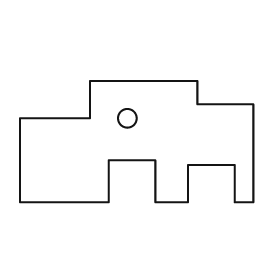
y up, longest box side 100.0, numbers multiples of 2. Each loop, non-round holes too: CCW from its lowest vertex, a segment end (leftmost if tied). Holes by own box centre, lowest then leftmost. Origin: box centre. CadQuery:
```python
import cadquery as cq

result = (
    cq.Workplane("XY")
    .moveTo(-50.0, -26.0)
    .lineTo(-12.0, -26.0)
    .lineTo(-12.0, -8.0)
    .lineTo(8.0, -8.0)
    .lineTo(8.0, -26.0)
    .lineTo(22.0, -26.0)
    .lineTo(22.0, -10.0)
    .lineTo(42.0, -10.0)
    .lineTo(42.0, -26.0)
    .lineTo(50.0, -26.0)
    .lineTo(50.0, 16.0)
    .lineTo(26.0, 16.0)
    .lineTo(26.0, 26.0)
    .lineTo(-20.0, 26.0)
    .lineTo(-20.0, 10.0)
    .lineTo(-50.0, 10.0)
    .close()
    .moveTo(-4.0, 10.0)
    .circle(4.0)
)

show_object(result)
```